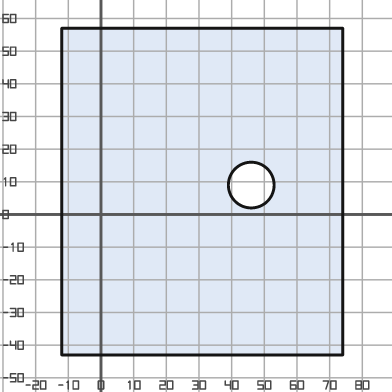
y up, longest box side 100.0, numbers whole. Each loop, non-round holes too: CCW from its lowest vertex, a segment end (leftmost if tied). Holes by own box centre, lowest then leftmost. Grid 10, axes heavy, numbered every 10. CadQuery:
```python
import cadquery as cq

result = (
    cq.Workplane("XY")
    .moveTo(-12.0, -43.0)
    .lineTo(74.0, -43.0)
    .lineTo(74.0, 57.0)
    .lineTo(-12.0, 57.0)
    .close()
    .moveTo(46.0, 9.0)
    .circle(7.0)
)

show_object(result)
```